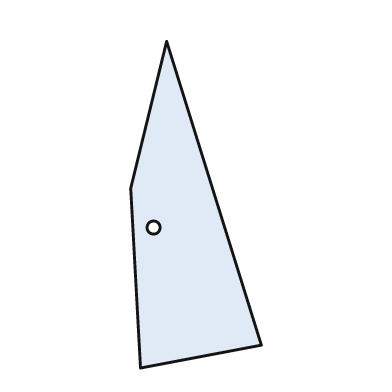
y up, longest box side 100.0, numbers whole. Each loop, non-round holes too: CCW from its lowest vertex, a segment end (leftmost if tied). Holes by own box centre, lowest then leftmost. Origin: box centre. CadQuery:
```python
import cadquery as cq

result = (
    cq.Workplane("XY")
    .moveTo(-17.0, -50.0)
    .lineTo(20.0, -43.0)
    .lineTo(-9.0, 50.0)
    .lineTo(-20.0, 5.0)
    .close()
    .moveTo(-13.0, -7.0)
    .circle(2.0)
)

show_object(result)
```